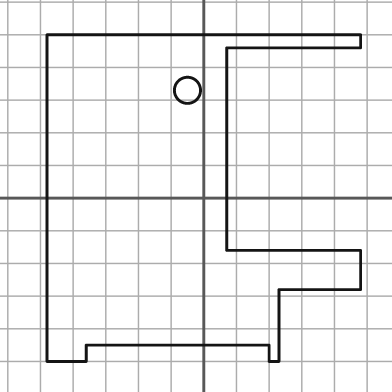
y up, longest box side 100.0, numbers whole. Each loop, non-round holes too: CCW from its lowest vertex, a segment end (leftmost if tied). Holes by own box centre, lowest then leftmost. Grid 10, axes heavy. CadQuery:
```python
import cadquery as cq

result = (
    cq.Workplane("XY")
    .moveTo(-48.0, -50.0)
    .lineTo(-36.0, -50.0)
    .lineTo(-36.0, -45.0)
    .lineTo(20.0, -45.0)
    .lineTo(20.0, -50.0)
    .lineTo(23.0, -50.0)
    .lineTo(23.0, -28.0)
    .lineTo(48.0, -28.0)
    .lineTo(48.0, -16.0)
    .lineTo(7.0, -16.0)
    .lineTo(7.0, 46.0)
    .lineTo(48.0, 46.0)
    .lineTo(48.0, 50.0)
    .lineTo(-48.0, 50.0)
    .close()
    .moveTo(-5.0, 33.0)
    .circle(4.0)
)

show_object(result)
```